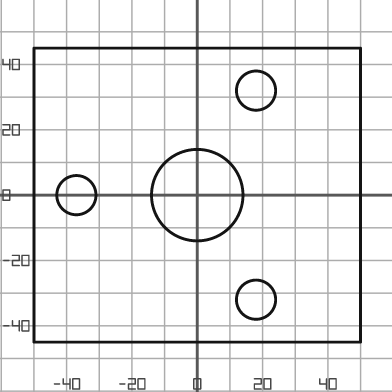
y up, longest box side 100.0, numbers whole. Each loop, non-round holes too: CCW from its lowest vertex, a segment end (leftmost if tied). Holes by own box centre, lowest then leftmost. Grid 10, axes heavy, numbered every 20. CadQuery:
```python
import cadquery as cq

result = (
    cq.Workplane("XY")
    .moveTo(-50.0, -45.0)
    .lineTo(50.0, -45.0)
    .lineTo(50.0, 45.0)
    .lineTo(-50.0, 45.0)
    .close()
    .moveTo(18.0, -32.0)
    .circle(6.0)
    .moveTo(-37.0, 0.0)
    .circle(6.0)
    .moveTo(0.0, 0.0)
    .circle(14.0)
    .moveTo(18.0, 32.0)
    .circle(6.0)
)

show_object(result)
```